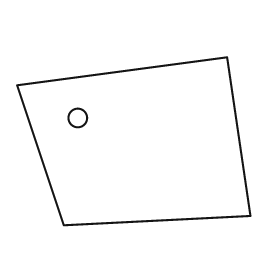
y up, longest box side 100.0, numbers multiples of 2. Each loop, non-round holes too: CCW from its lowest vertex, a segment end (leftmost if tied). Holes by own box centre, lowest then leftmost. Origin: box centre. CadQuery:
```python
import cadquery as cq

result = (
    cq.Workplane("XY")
    .moveTo(-30.0, -36.0)
    .lineTo(50.0, -32.0)
    .lineTo(40.0, 36.0)
    .lineTo(-50.0, 24.0)
    .close()
    .moveTo(-24.0, 10.0)
    .circle(4.0)
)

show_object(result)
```